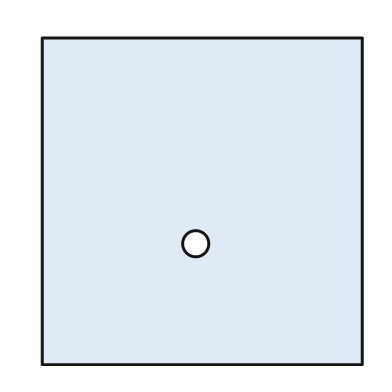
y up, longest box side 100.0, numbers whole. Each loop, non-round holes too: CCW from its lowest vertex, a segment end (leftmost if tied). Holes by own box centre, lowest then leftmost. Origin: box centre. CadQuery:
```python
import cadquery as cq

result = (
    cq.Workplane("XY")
    .moveTo(-49.0, -50.0)
    .lineTo(49.0, -50.0)
    .lineTo(49.0, 50.0)
    .lineTo(-49.0, 50.0)
    .close()
    .moveTo(-2.0, -13.0)
    .circle(4.0)
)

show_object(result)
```